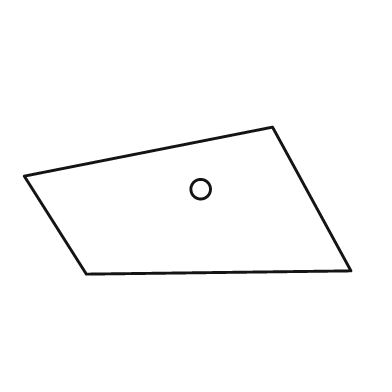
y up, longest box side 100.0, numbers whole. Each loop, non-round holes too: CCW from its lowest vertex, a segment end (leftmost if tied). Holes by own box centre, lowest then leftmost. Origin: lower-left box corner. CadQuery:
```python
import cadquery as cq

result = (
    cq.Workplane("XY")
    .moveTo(19.0, 0.0)
    .lineTo(100.0, 1.0)
    .lineTo(76.0, 45.0)
    .lineTo(0.0, 30.0)
    .close()
    .moveTo(54.0, 26.0)
    .circle(3.0)
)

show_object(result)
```